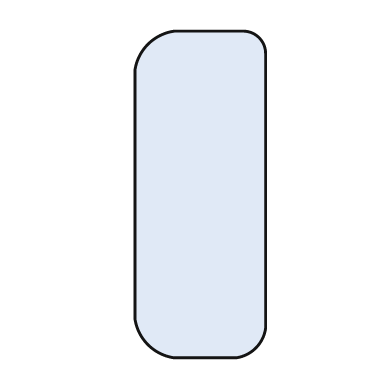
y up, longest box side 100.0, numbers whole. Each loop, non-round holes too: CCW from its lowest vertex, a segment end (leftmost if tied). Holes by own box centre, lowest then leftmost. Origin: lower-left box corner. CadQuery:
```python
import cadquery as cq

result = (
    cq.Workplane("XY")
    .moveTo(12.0, 0.0)
    .lineTo(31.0, 0.0)
    .threePointArc((37.0, 3.0), (40.0, 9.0))
    .lineTo(40.0, 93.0)
    .threePointArc((38.0, 98.0), (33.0, 100.0))
    .lineTo(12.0, 100.0)
    .threePointArc((4.0, 96.0), (0.0, 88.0))
    .lineTo(0.0, 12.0)
    .threePointArc((4.0, 4.0), (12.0, 0.0))
    .close()
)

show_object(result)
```